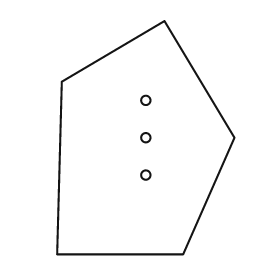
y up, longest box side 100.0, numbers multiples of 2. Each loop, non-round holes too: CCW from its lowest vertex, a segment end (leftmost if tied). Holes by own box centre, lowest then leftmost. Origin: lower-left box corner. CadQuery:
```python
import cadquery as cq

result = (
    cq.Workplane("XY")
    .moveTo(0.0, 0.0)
    .lineTo(54.0, 0.0)
    .lineTo(76.0, 50.0)
    .lineTo(46.0, 100.0)
    .lineTo(2.0, 74.0)
    .close()
    .moveTo(38.0, 34.0)
    .circle(2.0)
    .moveTo(38.0, 50.0)
    .circle(2.0)
    .moveTo(38.0, 66.0)
    .circle(2.0)
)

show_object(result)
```